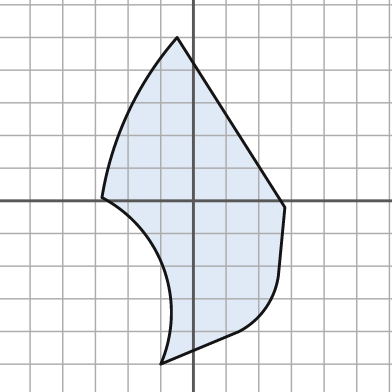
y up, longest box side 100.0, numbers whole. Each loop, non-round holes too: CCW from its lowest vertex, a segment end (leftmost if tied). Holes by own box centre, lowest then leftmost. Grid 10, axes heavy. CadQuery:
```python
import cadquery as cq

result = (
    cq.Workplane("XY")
    .moveTo(-10.0, -50.0)
    .lineTo(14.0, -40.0)
    .threePointArc((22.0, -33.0), (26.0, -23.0))
    .lineTo(28.0, -2.0)
    .lineTo(-5.0, 50.0)
    .threePointArc((-20.0, 27.0), (-28.0, 1.0))
    .threePointArc((-9.0, -21.0), (-10.0, -50.0))
    .close()
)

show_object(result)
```